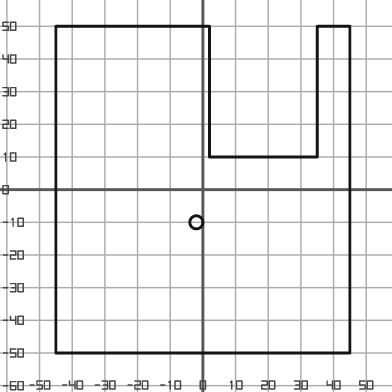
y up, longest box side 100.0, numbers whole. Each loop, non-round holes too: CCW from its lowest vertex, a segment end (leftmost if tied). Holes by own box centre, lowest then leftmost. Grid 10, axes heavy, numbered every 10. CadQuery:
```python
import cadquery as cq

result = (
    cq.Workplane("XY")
    .moveTo(-45.0, -50.0)
    .lineTo(45.0, -50.0)
    .lineTo(45.0, 50.0)
    .lineTo(35.0, 50.0)
    .lineTo(35.0, 10.0)
    .lineTo(2.0, 10.0)
    .lineTo(2.0, 50.0)
    .lineTo(-45.0, 50.0)
    .close()
    .moveTo(-2.0, -10.0)
    .circle(2.0)
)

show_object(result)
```